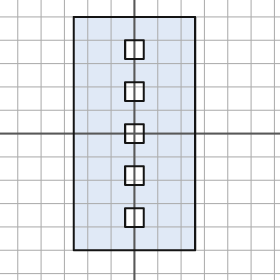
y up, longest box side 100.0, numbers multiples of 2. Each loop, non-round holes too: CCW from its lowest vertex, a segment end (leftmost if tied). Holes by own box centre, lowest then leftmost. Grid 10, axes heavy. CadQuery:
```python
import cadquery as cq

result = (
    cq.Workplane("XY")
    .moveTo(-26.0, -50.0)
    .lineTo(26.0, -50.0)
    .lineTo(26.0, 50.0)
    .lineTo(-26.0, 50.0)
    .close()
    .moveTo(-4.0, -40.0)
    .lineTo(4.0, -40.0)
    .lineTo(4.0, -32.0)
    .lineTo(-4.0, -32.0)
    .close()
    .moveTo(-4.0, -22.0)
    .lineTo(4.0, -22.0)
    .lineTo(4.0, -14.0)
    .lineTo(-4.0, -14.0)
    .close()
    .moveTo(-4.0, -4.0)
    .lineTo(4.0, -4.0)
    .lineTo(4.0, 4.0)
    .lineTo(-4.0, 4.0)
    .close()
    .moveTo(-4.0, 14.0)
    .lineTo(4.0, 14.0)
    .lineTo(4.0, 22.0)
    .lineTo(-4.0, 22.0)
    .close()
    .moveTo(-4.0, 32.0)
    .lineTo(4.0, 32.0)
    .lineTo(4.0, 40.0)
    .lineTo(-4.0, 40.0)
    .close()
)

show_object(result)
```